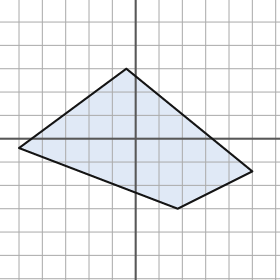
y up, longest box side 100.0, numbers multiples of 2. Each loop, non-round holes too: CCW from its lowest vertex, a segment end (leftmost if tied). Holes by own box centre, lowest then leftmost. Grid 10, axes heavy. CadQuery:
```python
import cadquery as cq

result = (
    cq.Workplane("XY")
    .moveTo(18.0, -30.0)
    .lineTo(50.0, -14.0)
    .lineTo(-4.0, 30.0)
    .lineTo(-50.0, -4.0)
    .close()
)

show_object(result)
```